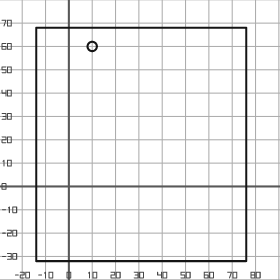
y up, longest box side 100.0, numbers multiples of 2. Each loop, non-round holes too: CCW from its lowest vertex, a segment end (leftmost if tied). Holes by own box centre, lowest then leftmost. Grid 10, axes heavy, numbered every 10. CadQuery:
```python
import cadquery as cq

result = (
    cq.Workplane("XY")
    .moveTo(-14.0, -32.0)
    .lineTo(76.0, -32.0)
    .lineTo(76.0, 68.0)
    .lineTo(-14.0, 68.0)
    .close()
    .moveTo(10.0, 60.0)
    .circle(2.0)
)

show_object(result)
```